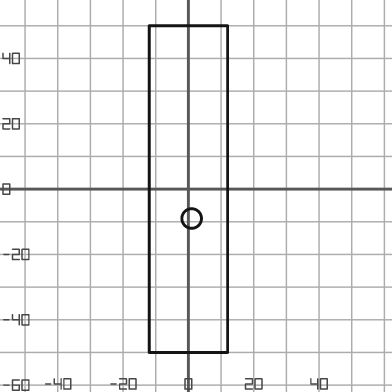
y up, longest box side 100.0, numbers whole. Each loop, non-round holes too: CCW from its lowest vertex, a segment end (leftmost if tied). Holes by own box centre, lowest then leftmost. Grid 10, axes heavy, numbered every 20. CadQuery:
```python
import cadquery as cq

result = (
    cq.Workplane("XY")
    .moveTo(-12.0, -50.0)
    .lineTo(12.0, -50.0)
    .lineTo(12.0, 50.0)
    .lineTo(-12.0, 50.0)
    .close()
    .moveTo(1.0, -9.0)
    .circle(3.0)
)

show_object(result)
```